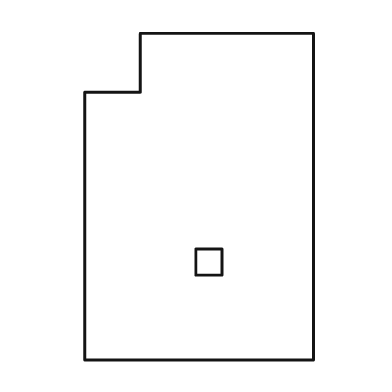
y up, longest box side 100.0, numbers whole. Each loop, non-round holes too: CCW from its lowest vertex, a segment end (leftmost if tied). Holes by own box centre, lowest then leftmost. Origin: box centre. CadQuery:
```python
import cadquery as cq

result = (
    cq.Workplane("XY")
    .moveTo(-35.0, -50.0)
    .lineTo(35.0, -50.0)
    .lineTo(35.0, 50.0)
    .lineTo(-18.0, 50.0)
    .lineTo(-18.0, 32.0)
    .lineTo(-35.0, 32.0)
    .close()
    .moveTo(-1.0, -24.0)
    .lineTo(7.0, -24.0)
    .lineTo(7.0, -16.0)
    .lineTo(-1.0, -16.0)
    .close()
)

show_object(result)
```